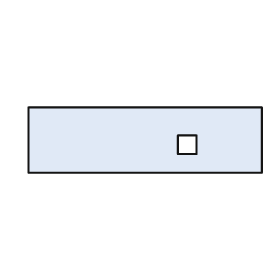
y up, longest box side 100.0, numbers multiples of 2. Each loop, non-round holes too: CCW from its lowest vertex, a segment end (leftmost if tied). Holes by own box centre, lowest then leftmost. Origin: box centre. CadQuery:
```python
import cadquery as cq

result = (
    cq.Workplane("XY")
    .moveTo(-50.0, -14.0)
    .lineTo(50.0, -14.0)
    .lineTo(50.0, 14.0)
    .lineTo(-50.0, 14.0)
    .close()
    .moveTo(14.0, -6.0)
    .lineTo(22.0, -6.0)
    .lineTo(22.0, 2.0)
    .lineTo(14.0, 2.0)
    .close()
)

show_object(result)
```